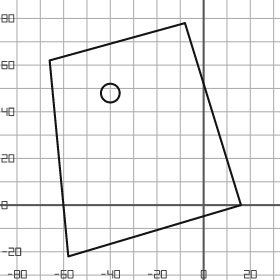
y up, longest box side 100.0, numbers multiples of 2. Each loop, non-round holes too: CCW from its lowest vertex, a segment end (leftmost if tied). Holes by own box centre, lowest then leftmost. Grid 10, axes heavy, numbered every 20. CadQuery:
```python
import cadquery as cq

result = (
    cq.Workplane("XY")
    .moveTo(-58.0, -22.0)
    .lineTo(16.0, 0.0)
    .lineTo(-8.0, 78.0)
    .lineTo(-66.0, 62.0)
    .close()
    .moveTo(-40.0, 48.0)
    .circle(4.0)
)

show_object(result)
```